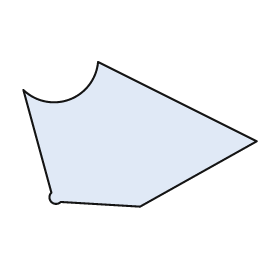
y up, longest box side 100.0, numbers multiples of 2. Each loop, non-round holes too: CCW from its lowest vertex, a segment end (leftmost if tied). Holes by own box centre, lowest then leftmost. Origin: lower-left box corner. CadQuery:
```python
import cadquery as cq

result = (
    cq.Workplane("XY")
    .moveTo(50.0, 0.0)
    .lineTo(100.0, 28.0)
    .lineTo(32.0, 62.0)
    .threePointArc((20.0, 46.0), (0.0, 50.0))
    .lineTo(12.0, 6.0)
    .threePointArc((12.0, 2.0), (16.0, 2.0))
    .close()
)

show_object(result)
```